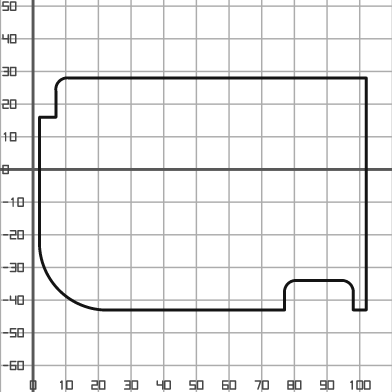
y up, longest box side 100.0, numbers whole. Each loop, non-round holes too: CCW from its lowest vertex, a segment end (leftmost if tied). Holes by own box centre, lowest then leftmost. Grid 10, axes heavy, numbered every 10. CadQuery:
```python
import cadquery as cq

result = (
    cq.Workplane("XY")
    .moveTo(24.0, -43.0)
    .lineTo(77.0, -43.0)
    .lineTo(77.0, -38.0)
    .threePointArc((78.0, -35.0), (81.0, -34.0))
    .lineTo(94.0, -34.0)
    .threePointArc((97.0, -35.0), (98.0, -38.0))
    .lineTo(98.0, -43.0)
    .lineTo(102.0, -43.0)
    .lineTo(102.0, 28.0)
    .lineTo(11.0, 28.0)
    .threePointArc((8.0, 27.0), (7.0, 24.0))
    .lineTo(7.0, 16.0)
    .lineTo(2.0, 16.0)
    .lineTo(2.0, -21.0)
    .threePointArc((8.0, -37.0), (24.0, -43.0))
    .close()
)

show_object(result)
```